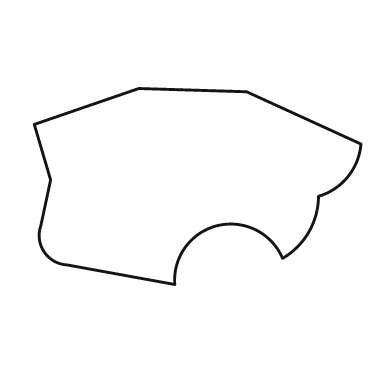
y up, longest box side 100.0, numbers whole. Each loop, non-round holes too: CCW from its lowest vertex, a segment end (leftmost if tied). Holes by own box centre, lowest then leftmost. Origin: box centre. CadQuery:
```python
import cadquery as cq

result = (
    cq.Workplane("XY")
    .moveTo(-7.0, -30.0)
    .threePointArc((6.0, -12.0), (26.0, -22.0))
    .threePointArc((34.0, -14.0), (37.0, -3.0))
    .threePointArc((46.0, 3.0), (50.0, 13.0))
    .lineTo(15.0, 29.0)
    .lineTo(-18.0, 30.0)
    .lineTo(-50.0, 19.0)
    .lineTo(-45.0, 2.0)
    .lineTo(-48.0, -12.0)
    .threePointArc((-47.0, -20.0), (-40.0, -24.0))
    .close()
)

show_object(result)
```